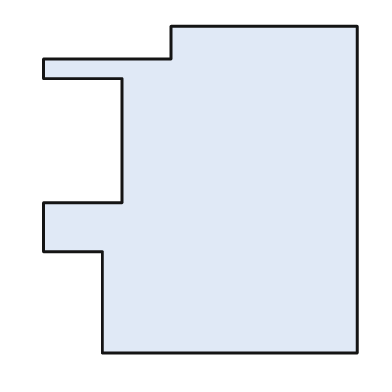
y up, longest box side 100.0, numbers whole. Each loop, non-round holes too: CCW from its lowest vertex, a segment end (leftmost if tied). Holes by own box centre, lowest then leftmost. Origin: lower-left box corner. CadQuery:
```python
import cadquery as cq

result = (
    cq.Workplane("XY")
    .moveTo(18.0, 0.0)
    .lineTo(96.0, 0.0)
    .lineTo(96.0, 100.0)
    .lineTo(39.0, 100.0)
    .lineTo(39.0, 90.0)
    .lineTo(0.0, 90.0)
    .lineTo(0.0, 84.0)
    .lineTo(24.0, 84.0)
    .lineTo(24.0, 46.0)
    .lineTo(0.0, 46.0)
    .lineTo(0.0, 31.0)
    .lineTo(18.0, 31.0)
    .close()
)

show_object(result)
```